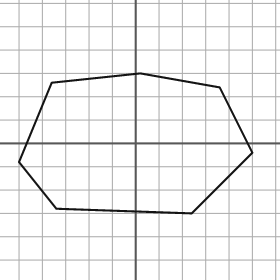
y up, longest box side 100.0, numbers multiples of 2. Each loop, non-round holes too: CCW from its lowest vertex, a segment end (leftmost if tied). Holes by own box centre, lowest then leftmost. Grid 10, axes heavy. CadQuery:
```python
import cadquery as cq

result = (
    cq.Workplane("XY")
    .moveTo(24.0, -30.0)
    .lineTo(50.0, -4.0)
    .lineTo(36.0, 24.0)
    .lineTo(2.0, 30.0)
    .lineTo(-36.0, 26.0)
    .lineTo(-50.0, -8.0)
    .lineTo(-34.0, -28.0)
    .close()
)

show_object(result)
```